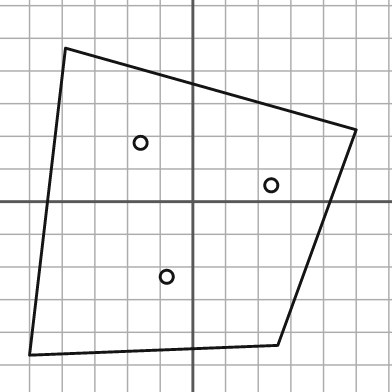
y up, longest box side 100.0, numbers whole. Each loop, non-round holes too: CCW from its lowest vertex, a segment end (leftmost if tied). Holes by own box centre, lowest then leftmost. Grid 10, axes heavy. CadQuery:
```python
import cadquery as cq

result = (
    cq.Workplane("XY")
    .moveTo(-50.0, -47.0)
    .lineTo(26.0, -44.0)
    .lineTo(50.0, 22.0)
    .lineTo(-39.0, 47.0)
    .close()
    .moveTo(-8.0, -23.0)
    .circle(2.0)
    .moveTo(24.0, 5.0)
    .circle(2.0)
    .moveTo(-16.0, 18.0)
    .circle(2.0)
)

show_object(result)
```